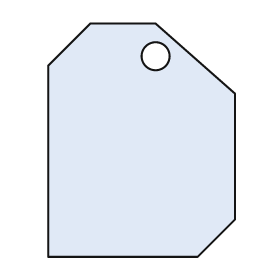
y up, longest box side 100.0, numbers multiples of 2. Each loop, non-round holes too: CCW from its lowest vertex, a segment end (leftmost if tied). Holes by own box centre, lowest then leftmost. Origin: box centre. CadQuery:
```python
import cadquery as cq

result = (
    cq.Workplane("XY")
    .moveTo(-40.0, -50.0)
    .lineTo(24.0, -50.0)
    .lineTo(40.0, -34.0)
    .lineTo(40.0, 20.0)
    .lineTo(6.0, 50.0)
    .lineTo(-22.0, 50.0)
    .lineTo(-40.0, 32.0)
    .close()
    .moveTo(6.0, 36.0)
    .circle(6.0)
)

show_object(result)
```